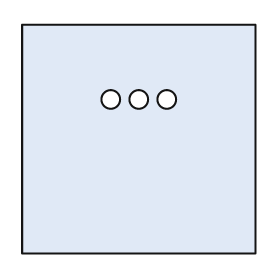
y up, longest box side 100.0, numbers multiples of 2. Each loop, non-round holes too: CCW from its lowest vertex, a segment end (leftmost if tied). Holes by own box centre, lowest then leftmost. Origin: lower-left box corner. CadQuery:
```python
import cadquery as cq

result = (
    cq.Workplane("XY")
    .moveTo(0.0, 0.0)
    .lineTo(100.0, 0.0)
    .lineTo(100.0, 98.0)
    .lineTo(0.0, 98.0)
    .close()
    .moveTo(38.0, 66.0)
    .circle(4.0)
    .moveTo(50.0, 66.0)
    .circle(4.0)
    .moveTo(62.0, 66.0)
    .circle(4.0)
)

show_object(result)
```